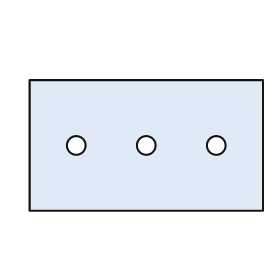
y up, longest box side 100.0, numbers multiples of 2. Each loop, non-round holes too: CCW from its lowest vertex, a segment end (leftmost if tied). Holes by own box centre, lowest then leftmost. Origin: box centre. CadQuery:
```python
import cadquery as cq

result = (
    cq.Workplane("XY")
    .moveTo(-50.0, -28.0)
    .lineTo(50.0, -28.0)
    .lineTo(50.0, 28.0)
    .lineTo(-50.0, 28.0)
    .close()
    .moveTo(-30.0, 0.0)
    .circle(4.0)
    .moveTo(0.0, 0.0)
    .circle(4.0)
    .moveTo(30.0, 0.0)
    .circle(4.0)
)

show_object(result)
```